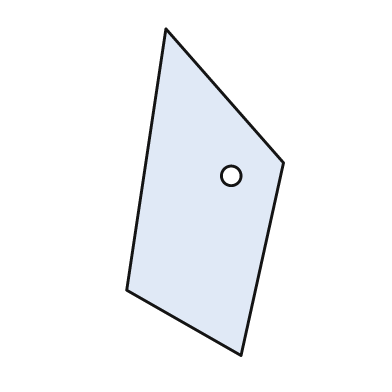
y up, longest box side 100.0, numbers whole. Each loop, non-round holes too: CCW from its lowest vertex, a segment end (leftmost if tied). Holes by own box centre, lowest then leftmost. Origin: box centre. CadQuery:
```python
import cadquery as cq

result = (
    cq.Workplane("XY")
    .moveTo(11.0, -50.0)
    .lineTo(24.0, 9.0)
    .lineTo(-12.0, 50.0)
    .lineTo(-24.0, -30.0)
    .close()
    .moveTo(8.0, 5.0)
    .circle(3.0)
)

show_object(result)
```